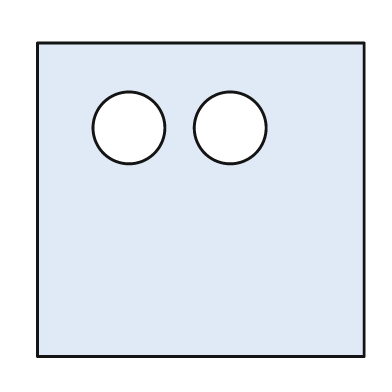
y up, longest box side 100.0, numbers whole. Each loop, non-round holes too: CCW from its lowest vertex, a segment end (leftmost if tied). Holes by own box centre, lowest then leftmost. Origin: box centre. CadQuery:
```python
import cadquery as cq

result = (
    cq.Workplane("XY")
    .moveTo(-50.0, -48.0)
    .lineTo(50.0, -48.0)
    .lineTo(50.0, 48.0)
    .lineTo(-50.0, 48.0)
    .close()
    .moveTo(-22.0, 22.0)
    .circle(11.0)
    .moveTo(9.0, 22.0)
    .circle(11.0)
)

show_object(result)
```